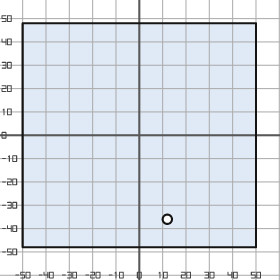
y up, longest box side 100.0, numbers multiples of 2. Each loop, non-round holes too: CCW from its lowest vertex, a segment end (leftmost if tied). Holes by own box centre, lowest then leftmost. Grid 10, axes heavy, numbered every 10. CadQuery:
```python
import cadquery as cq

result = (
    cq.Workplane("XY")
    .moveTo(-50.0, -48.0)
    .lineTo(50.0, -48.0)
    .lineTo(50.0, 48.0)
    .lineTo(-50.0, 48.0)
    .close()
    .moveTo(12.0, -36.0)
    .circle(2.0)
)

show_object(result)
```